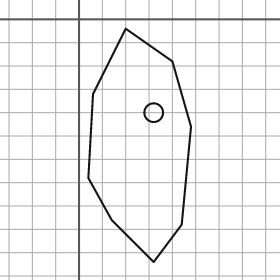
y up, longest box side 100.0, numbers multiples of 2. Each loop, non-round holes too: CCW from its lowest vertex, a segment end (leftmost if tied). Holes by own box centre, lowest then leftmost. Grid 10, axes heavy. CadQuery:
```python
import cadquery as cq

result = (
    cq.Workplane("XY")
    .moveTo(32.0, -104.0)
    .lineTo(44.0, -88.0)
    .lineTo(48.0, -46.0)
    .lineTo(40.0, -18.0)
    .lineTo(20.0, -4.0)
    .lineTo(6.0, -32.0)
    .lineTo(4.0, -68.0)
    .lineTo(14.0, -86.0)
    .close()
    .moveTo(32.0, -40.0)
    .circle(4.0)
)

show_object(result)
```